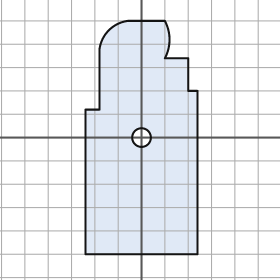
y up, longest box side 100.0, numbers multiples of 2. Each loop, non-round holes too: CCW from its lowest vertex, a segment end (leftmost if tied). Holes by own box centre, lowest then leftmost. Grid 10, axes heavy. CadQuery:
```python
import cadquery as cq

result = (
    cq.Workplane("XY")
    .moveTo(-24.0, -50.0)
    .lineTo(24.0, -50.0)
    .lineTo(24.0, 20.0)
    .lineTo(20.0, 20.0)
    .lineTo(20.0, 34.0)
    .lineTo(10.0, 34.0)
    .threePointArc((12.0, 42.0), (10.0, 50.0))
    .lineTo(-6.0, 50.0)
    .threePointArc((-14.0, 46.0), (-18.0, 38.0))
    .lineTo(-18.0, 12.0)
    .lineTo(-24.0, 12.0)
    .close()
    .moveTo(0.0, 0.0)
    .circle(4.0)
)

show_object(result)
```